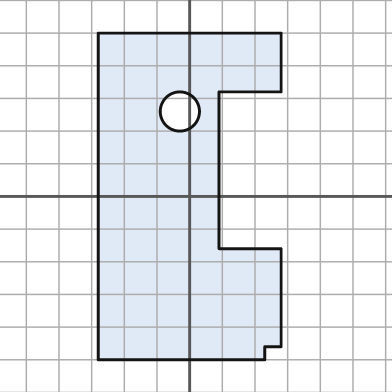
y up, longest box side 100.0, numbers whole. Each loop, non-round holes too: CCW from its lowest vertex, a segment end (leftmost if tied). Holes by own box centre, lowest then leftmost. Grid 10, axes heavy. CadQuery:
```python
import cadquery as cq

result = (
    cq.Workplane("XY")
    .moveTo(-28.0, -50.0)
    .lineTo(23.0, -50.0)
    .lineTo(23.0, -46.0)
    .lineTo(28.0, -46.0)
    .lineTo(28.0, -16.0)
    .lineTo(9.0, -16.0)
    .lineTo(9.0, 32.0)
    .lineTo(28.0, 32.0)
    .lineTo(28.0, 50.0)
    .lineTo(-28.0, 50.0)
    .close()
    .moveTo(-3.0, 26.0)
    .circle(6.0)
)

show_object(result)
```